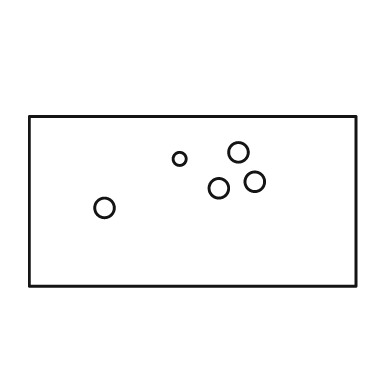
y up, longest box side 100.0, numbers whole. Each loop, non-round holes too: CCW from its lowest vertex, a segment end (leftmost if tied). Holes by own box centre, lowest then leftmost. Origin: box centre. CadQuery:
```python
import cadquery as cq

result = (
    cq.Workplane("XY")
    .moveTo(-50.0, -26.0)
    .lineTo(50.0, -26.0)
    .lineTo(50.0, 26.0)
    .lineTo(-50.0, 26.0)
    .close()
    .moveTo(-27.0, -2.0)
    .circle(3.0)
    .moveTo(8.0, 4.0)
    .circle(3.0)
    .moveTo(19.0, 6.0)
    .circle(3.0)
    .moveTo(-4.0, 13.0)
    .circle(2.0)
    .moveTo(14.0, 15.0)
    .circle(3.0)
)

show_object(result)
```